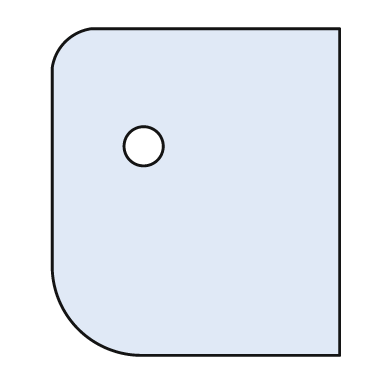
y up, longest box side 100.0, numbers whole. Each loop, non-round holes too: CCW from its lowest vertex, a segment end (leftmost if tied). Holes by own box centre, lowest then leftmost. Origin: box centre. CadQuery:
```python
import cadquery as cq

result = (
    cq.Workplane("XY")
    .moveTo(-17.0, -50.0)
    .lineTo(44.0, -50.0)
    .lineTo(44.0, 50.0)
    .lineTo(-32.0, 50.0)
    .threePointArc((-40.0, 46.0), (-44.0, 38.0))
    .lineTo(-44.0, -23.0)
    .threePointArc((-36.0, -42.0), (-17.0, -50.0))
    .close()
    .moveTo(-16.0, 14.0)
    .circle(6.0)
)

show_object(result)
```